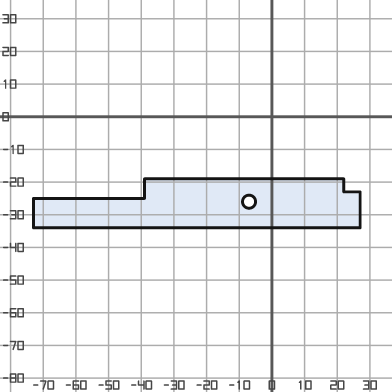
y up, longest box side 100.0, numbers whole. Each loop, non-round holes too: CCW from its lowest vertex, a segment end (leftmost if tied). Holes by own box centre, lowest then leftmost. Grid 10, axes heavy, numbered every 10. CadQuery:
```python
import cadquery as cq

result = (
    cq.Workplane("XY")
    .moveTo(-73.0, -34.0)
    .lineTo(27.0, -34.0)
    .lineTo(27.0, -23.0)
    .lineTo(22.0, -23.0)
    .lineTo(22.0, -19.0)
    .lineTo(-39.0, -19.0)
    .lineTo(-39.0, -25.0)
    .lineTo(-73.0, -25.0)
    .close()
    .moveTo(-7.0, -26.0)
    .circle(2.0)
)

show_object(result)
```